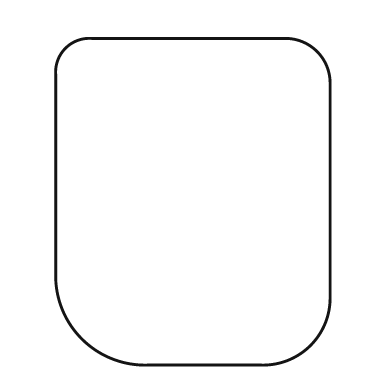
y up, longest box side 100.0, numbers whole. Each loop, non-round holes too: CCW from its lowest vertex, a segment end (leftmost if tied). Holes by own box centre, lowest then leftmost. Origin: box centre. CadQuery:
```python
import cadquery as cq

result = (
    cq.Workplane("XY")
    .moveTo(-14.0, -50.0)
    .lineTo(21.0, -50.0)
    .threePointArc((36.0, -44.0), (42.0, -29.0))
    .lineTo(42.0, 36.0)
    .threePointArc((38.0, 46.0), (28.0, 50.0))
    .lineTo(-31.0, 50.0)
    .threePointArc((-39.0, 47.0), (-42.0, 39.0))
    .lineTo(-42.0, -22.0)
    .threePointArc((-34.0, -42.0), (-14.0, -50.0))
    .close()
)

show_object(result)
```